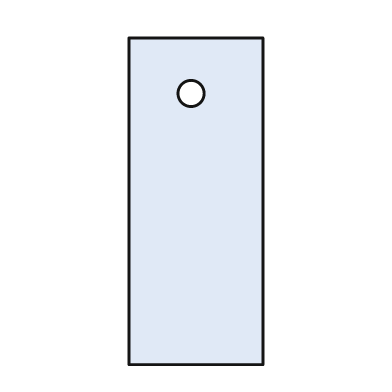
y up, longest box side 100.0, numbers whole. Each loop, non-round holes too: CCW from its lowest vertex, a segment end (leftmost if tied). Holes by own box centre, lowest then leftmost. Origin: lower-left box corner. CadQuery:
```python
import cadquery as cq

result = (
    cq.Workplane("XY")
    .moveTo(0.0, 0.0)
    .lineTo(41.0, 0.0)
    .lineTo(41.0, 100.0)
    .lineTo(0.0, 100.0)
    .close()
    .moveTo(19.0, 83.0)
    .circle(4.0)
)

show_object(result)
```